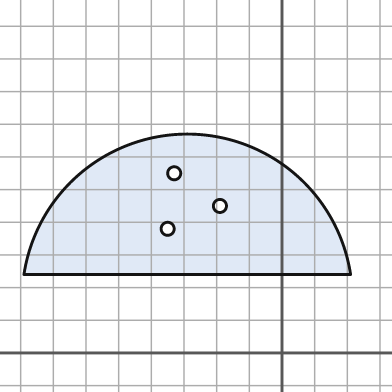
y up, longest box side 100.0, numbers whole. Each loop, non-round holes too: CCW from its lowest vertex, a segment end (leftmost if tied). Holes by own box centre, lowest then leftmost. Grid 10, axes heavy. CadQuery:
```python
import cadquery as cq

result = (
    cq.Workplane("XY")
    .moveTo(-79.0, 24.0)
    .lineTo(21.0, 24.0)
    .threePointArc((-29.0, 67.0), (-79.0, 24.0))
    .close()
    .moveTo(-35.0, 38.0)
    .circle(2.0)
    .moveTo(-19.0, 45.0)
    .circle(2.0)
    .moveTo(-33.0, 55.0)
    .circle(2.0)
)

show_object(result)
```